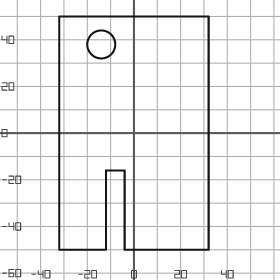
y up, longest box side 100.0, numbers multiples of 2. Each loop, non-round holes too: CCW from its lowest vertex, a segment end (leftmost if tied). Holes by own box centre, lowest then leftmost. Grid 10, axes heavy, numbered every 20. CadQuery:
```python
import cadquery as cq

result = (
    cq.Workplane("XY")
    .moveTo(-32.0, -50.0)
    .lineTo(-12.0, -50.0)
    .lineTo(-12.0, -16.0)
    .lineTo(-4.0, -16.0)
    .lineTo(-4.0, -50.0)
    .lineTo(32.0, -50.0)
    .lineTo(32.0, 50.0)
    .lineTo(-32.0, 50.0)
    .close()
    .moveTo(-14.0, 38.0)
    .circle(6.0)
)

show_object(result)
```